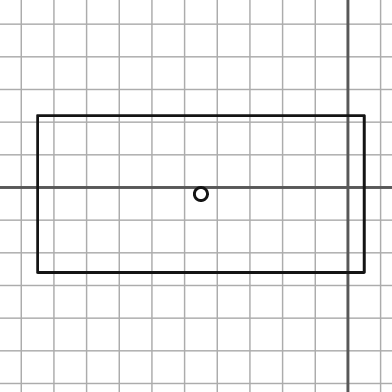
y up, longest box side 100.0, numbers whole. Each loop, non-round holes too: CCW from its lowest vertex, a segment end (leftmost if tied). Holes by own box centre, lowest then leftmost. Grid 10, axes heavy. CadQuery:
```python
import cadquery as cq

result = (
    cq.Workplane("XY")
    .moveTo(-95.0, -26.0)
    .lineTo(5.0, -26.0)
    .lineTo(5.0, 22.0)
    .lineTo(-95.0, 22.0)
    .close()
    .moveTo(-45.0, -2.0)
    .circle(2.0)
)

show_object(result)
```